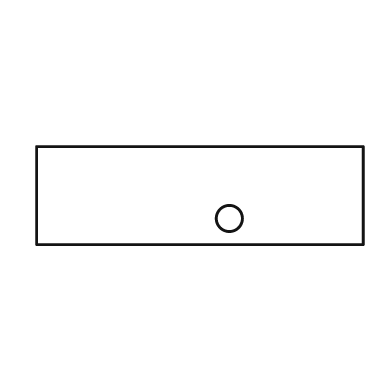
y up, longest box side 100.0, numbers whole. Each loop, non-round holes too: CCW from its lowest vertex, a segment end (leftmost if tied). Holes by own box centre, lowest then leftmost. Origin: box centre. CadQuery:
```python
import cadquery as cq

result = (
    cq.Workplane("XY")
    .moveTo(-50.0, -15.0)
    .lineTo(50.0, -15.0)
    .lineTo(50.0, 15.0)
    .lineTo(-50.0, 15.0)
    .close()
    .moveTo(9.0, -7.0)
    .circle(4.0)
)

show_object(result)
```